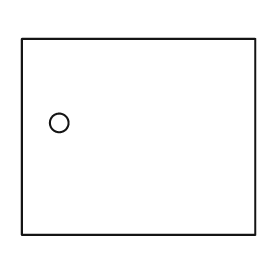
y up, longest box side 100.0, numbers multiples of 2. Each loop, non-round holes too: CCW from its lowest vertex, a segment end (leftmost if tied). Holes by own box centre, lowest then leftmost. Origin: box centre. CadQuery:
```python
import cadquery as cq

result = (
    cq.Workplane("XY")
    .moveTo(-50.0, -42.0)
    .lineTo(50.0, -42.0)
    .lineTo(50.0, 42.0)
    .lineTo(-50.0, 42.0)
    .close()
    .moveTo(-34.0, 6.0)
    .circle(4.0)
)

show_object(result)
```